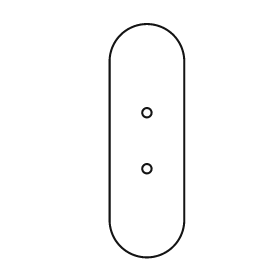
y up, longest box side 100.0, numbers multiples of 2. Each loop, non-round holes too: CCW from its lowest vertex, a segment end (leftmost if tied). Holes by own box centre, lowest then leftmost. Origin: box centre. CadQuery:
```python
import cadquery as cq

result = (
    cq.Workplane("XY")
    .moveTo(-16.0, -34.0)
    .threePointArc((0.0, -50.0), (16.0, -34.0))
    .lineTo(16.0, 34.0)
    .threePointArc((0.0, 50.0), (-16.0, 34.0))
    .close()
    .moveTo(0.0, -12.0)
    .circle(2.0)
    .moveTo(0.0, 12.0)
    .circle(2.0)
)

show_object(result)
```